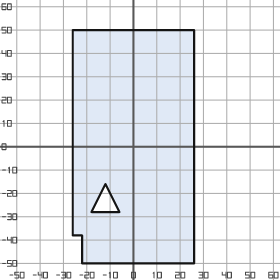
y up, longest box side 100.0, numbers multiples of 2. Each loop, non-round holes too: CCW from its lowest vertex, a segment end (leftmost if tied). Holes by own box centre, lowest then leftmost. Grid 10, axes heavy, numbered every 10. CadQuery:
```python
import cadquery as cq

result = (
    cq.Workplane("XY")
    .moveTo(-22.0, -50.0)
    .lineTo(26.0, -50.0)
    .lineTo(26.0, 50.0)
    .lineTo(-26.0, 50.0)
    .lineTo(-26.0, -38.0)
    .lineTo(-22.0, -38.0)
    .close()
    .moveTo(-18.0, -28.0)
    .lineTo(-6.0, -28.0)
    .lineTo(-12.0, -16.0)
    .close()
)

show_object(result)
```